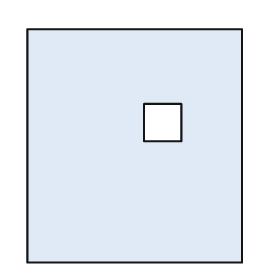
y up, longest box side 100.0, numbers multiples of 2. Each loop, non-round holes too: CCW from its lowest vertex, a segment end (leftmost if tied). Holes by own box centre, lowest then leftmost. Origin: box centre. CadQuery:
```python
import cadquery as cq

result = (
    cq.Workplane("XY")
    .moveTo(-46.0, -50.0)
    .lineTo(46.0, -50.0)
    .lineTo(46.0, 50.0)
    .lineTo(-46.0, 50.0)
    .close()
    .moveTo(4.0, 2.0)
    .lineTo(20.0, 2.0)
    .lineTo(20.0, 18.0)
    .lineTo(4.0, 18.0)
    .close()
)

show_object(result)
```